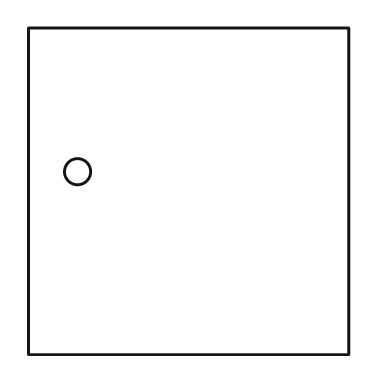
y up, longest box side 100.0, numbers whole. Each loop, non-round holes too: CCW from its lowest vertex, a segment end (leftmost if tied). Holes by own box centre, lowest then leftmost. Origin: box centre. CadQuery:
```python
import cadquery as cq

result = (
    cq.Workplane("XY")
    .moveTo(-49.0, -50.0)
    .lineTo(49.0, -50.0)
    .lineTo(49.0, 50.0)
    .lineTo(-49.0, 50.0)
    .close()
    .moveTo(-34.0, 6.0)
    .circle(4.0)
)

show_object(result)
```